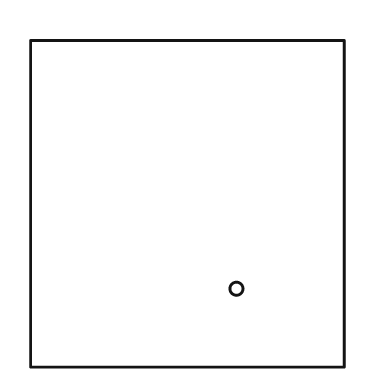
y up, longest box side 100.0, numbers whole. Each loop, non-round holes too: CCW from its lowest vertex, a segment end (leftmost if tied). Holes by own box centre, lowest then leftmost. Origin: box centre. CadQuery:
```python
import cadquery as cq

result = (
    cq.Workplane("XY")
    .moveTo(-48.0, -50.0)
    .lineTo(48.0, -50.0)
    .lineTo(48.0, 50.0)
    .lineTo(-48.0, 50.0)
    .close()
    .moveTo(15.0, -26.0)
    .circle(2.0)
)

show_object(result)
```